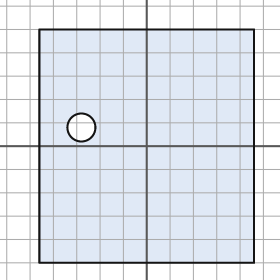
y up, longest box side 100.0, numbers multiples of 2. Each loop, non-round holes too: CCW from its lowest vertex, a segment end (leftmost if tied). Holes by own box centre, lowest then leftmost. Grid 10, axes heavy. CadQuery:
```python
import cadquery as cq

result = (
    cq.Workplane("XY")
    .moveTo(-46.0, -50.0)
    .lineTo(46.0, -50.0)
    .lineTo(46.0, 50.0)
    .lineTo(-46.0, 50.0)
    .close()
    .moveTo(-28.0, 8.0)
    .circle(6.0)
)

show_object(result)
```